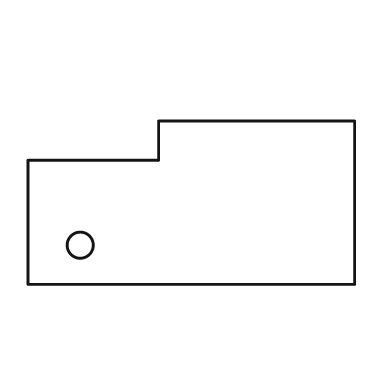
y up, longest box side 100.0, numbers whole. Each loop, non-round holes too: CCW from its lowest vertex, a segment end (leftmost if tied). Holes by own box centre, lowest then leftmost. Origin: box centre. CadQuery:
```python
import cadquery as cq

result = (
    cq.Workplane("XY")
    .moveTo(-50.0, -25.0)
    .lineTo(50.0, -25.0)
    .lineTo(50.0, 25.0)
    .lineTo(-10.0, 25.0)
    .lineTo(-10.0, 13.0)
    .lineTo(-50.0, 13.0)
    .close()
    .moveTo(-34.0, -13.0)
    .circle(4.0)
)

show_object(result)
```